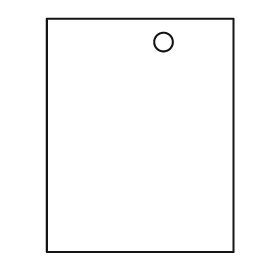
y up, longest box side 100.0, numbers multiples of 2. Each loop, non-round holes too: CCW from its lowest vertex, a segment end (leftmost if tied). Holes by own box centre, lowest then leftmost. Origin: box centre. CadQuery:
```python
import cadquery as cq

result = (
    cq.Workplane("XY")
    .moveTo(-40.0, -50.0)
    .lineTo(40.0, -50.0)
    .lineTo(40.0, 50.0)
    .lineTo(-40.0, 50.0)
    .close()
    .moveTo(10.0, 40.0)
    .circle(4.0)
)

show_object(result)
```